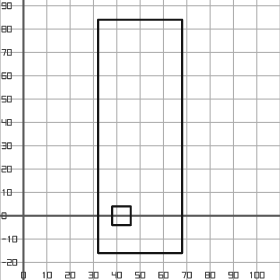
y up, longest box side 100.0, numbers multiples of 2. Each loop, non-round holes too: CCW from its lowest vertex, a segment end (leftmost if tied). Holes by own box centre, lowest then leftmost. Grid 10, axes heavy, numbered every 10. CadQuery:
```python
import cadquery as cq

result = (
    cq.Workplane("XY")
    .moveTo(32.0, -16.0)
    .lineTo(68.0, -16.0)
    .lineTo(68.0, 84.0)
    .lineTo(32.0, 84.0)
    .close()
    .moveTo(38.0, -4.0)
    .lineTo(46.0, -4.0)
    .lineTo(46.0, 4.0)
    .lineTo(38.0, 4.0)
    .close()
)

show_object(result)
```